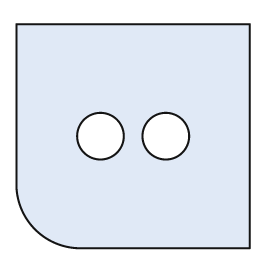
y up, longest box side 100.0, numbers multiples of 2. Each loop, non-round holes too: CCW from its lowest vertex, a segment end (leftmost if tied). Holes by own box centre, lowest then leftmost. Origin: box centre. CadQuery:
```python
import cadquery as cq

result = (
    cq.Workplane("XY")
    .moveTo(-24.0, -48.0)
    .lineTo(50.0, -48.0)
    .lineTo(50.0, 48.0)
    .lineTo(-50.0, 48.0)
    .lineTo(-50.0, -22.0)
    .threePointArc((-42.0, -40.0), (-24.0, -48.0))
    .close()
    .moveTo(-14.0, 0.0)
    .circle(10.0)
    .moveTo(14.0, 0.0)
    .circle(10.0)
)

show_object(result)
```